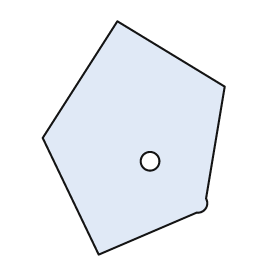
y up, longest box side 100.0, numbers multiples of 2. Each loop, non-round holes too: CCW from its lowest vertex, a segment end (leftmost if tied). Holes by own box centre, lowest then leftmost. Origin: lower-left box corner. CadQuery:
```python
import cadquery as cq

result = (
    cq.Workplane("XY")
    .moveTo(24.0, 0.0)
    .lineTo(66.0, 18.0)
    .threePointArc((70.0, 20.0), (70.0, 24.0))
    .lineTo(78.0, 72.0)
    .lineTo(32.0, 100.0)
    .lineTo(0.0, 50.0)
    .close()
    .moveTo(46.0, 40.0)
    .circle(4.0)
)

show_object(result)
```